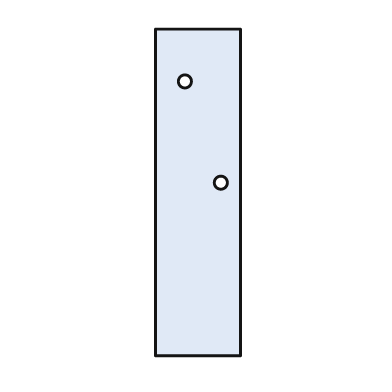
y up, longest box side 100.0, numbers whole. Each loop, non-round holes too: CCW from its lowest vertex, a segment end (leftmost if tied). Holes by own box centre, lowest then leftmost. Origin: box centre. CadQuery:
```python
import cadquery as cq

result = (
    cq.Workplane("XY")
    .moveTo(-13.0, -50.0)
    .lineTo(13.0, -50.0)
    .lineTo(13.0, 50.0)
    .lineTo(-13.0, 50.0)
    .close()
    .moveTo(7.0, 3.0)
    .circle(2.0)
    .moveTo(-4.0, 34.0)
    .circle(2.0)
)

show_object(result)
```